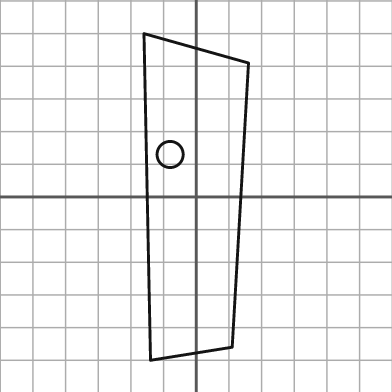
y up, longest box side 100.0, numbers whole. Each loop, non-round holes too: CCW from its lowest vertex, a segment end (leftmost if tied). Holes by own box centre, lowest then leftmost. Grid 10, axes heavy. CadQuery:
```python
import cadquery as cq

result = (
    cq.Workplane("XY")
    .moveTo(-14.0, -50.0)
    .lineTo(11.0, -46.0)
    .lineTo(16.0, 41.0)
    .lineTo(-16.0, 50.0)
    .close()
    .moveTo(-8.0, 13.0)
    .circle(4.0)
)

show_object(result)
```